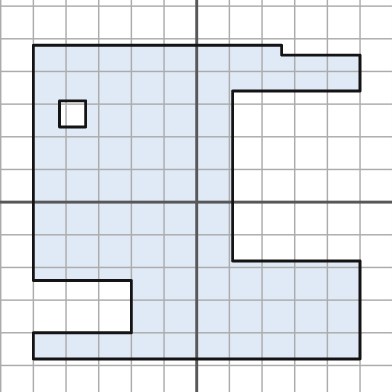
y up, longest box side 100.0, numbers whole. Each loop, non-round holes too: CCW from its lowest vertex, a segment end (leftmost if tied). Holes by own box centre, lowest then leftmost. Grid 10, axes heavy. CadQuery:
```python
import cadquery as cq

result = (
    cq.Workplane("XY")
    .moveTo(-50.0, -48.0)
    .lineTo(50.0, -48.0)
    .lineTo(50.0, -18.0)
    .lineTo(11.0, -18.0)
    .lineTo(11.0, 34.0)
    .lineTo(50.0, 34.0)
    .lineTo(50.0, 45.0)
    .lineTo(26.0, 45.0)
    .lineTo(26.0, 48.0)
    .lineTo(-50.0, 48.0)
    .lineTo(-50.0, -24.0)
    .lineTo(-20.0, -24.0)
    .lineTo(-20.0, -40.0)
    .lineTo(-50.0, -40.0)
    .close()
    .moveTo(-42.0, 23.0)
    .lineTo(-34.0, 23.0)
    .lineTo(-34.0, 31.0)
    .lineTo(-42.0, 31.0)
    .close()
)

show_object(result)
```